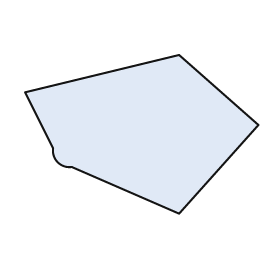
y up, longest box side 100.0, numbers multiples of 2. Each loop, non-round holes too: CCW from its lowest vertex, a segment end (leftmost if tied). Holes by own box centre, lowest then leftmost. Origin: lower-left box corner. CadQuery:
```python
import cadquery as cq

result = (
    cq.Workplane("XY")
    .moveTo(66.0, 0.0)
    .lineTo(100.0, 38.0)
    .lineTo(66.0, 68.0)
    .lineTo(0.0, 52.0)
    .lineTo(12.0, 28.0)
    .threePointArc((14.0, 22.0), (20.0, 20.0))
    .close()
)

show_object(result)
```